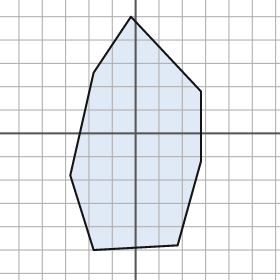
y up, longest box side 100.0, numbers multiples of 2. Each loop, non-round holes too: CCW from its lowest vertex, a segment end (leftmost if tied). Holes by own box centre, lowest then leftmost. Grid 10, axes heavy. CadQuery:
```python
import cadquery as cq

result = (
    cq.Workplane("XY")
    .moveTo(-18.0, -50.0)
    .lineTo(18.0, -48.0)
    .lineTo(28.0, -12.0)
    .lineTo(28.0, 18.0)
    .lineTo(-2.0, 50.0)
    .lineTo(-18.0, 26.0)
    .lineTo(-28.0, -18.0)
    .close()
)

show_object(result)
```